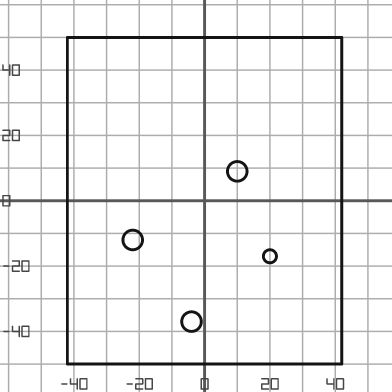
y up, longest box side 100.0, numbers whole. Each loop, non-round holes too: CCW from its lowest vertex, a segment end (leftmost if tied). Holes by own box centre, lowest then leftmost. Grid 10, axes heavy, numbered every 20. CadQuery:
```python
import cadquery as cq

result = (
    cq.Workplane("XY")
    .moveTo(-42.0, -50.0)
    .lineTo(42.0, -50.0)
    .lineTo(42.0, 50.0)
    .lineTo(-42.0, 50.0)
    .close()
    .moveTo(-4.0, -37.0)
    .circle(3.0)
    .moveTo(20.0, -17.0)
    .circle(2.0)
    .moveTo(-22.0, -12.0)
    .circle(3.0)
    .moveTo(10.0, 9.0)
    .circle(3.0)
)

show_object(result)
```